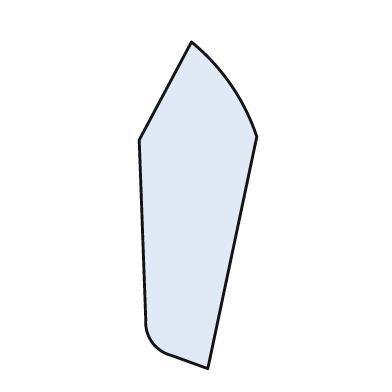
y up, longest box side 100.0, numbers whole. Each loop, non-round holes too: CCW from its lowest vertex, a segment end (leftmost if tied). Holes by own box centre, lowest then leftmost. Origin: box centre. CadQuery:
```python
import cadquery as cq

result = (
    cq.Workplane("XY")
    .moveTo(3.0, -50.0)
    .lineTo(18.0, 21.0)
    .threePointArc((10.0, 37.0), (-2.0, 50.0))
    .lineTo(-18.0, 20.0)
    .lineTo(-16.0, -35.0)
    .threePointArc((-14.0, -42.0), (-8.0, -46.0))
    .close()
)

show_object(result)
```